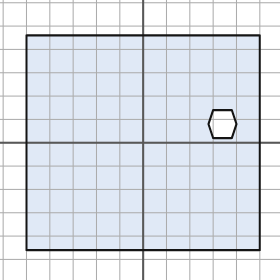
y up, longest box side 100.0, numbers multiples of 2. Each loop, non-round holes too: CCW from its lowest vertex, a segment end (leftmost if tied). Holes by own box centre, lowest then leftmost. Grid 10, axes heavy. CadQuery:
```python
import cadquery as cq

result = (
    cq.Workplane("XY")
    .moveTo(-50.0, -46.0)
    .lineTo(50.0, -46.0)
    .lineTo(50.0, 46.0)
    .lineTo(-50.0, 46.0)
    .close()
    .moveTo(30.0, 2.0)
    .lineTo(38.0, 2.0)
    .lineTo(40.0, 8.0)
    .lineTo(38.0, 14.0)
    .lineTo(30.0, 14.0)
    .lineTo(28.0, 8.0)
    .close()
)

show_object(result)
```